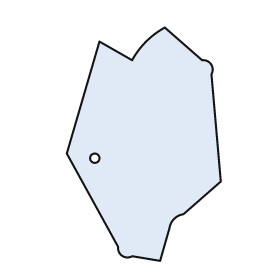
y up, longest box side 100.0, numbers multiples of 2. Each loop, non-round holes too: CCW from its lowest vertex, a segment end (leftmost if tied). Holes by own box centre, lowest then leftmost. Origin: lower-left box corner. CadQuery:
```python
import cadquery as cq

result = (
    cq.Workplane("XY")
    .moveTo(40.0, 0.0)
    .lineTo(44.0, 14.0)
    .threePointArc((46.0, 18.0), (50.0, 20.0))
    .lineTo(66.0, 34.0)
    .lineTo(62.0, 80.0)
    .threePointArc((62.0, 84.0), (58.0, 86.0))
    .lineTo(42.0, 100.0)
    .threePointArc((34.0, 94.0), (28.0, 86.0))
    .lineTo(14.0, 94.0)
    .lineTo(0.0, 46.0)
    .lineTo(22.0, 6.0)
    .threePointArc((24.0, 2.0), (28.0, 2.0))
    .close()
    .moveTo(12.0, 44.0)
    .circle(2.0)
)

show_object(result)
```